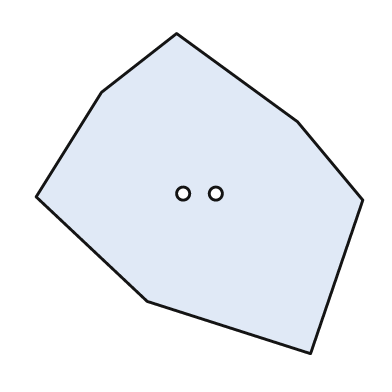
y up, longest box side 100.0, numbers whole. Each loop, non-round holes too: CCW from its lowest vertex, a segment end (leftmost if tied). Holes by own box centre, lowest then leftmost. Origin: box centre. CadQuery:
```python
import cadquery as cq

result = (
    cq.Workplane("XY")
    .moveTo(34.0, -49.0)
    .lineTo(50.0, -2.0)
    .lineTo(30.0, 22.0)
    .lineTo(-7.0, 49.0)
    .lineTo(-30.0, 31.0)
    .lineTo(-50.0, -1.0)
    .lineTo(-16.0, -33.0)
    .close()
    .moveTo(-5.0, 0.0)
    .circle(2.0)
    .moveTo(5.0, 0.0)
    .circle(2.0)
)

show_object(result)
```